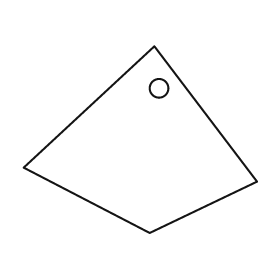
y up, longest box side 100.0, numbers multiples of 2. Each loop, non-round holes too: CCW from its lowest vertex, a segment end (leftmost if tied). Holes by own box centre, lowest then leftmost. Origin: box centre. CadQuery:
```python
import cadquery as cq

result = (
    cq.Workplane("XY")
    .moveTo(4.0, -40.0)
    .lineTo(50.0, -18.0)
    .lineTo(6.0, 40.0)
    .lineTo(-50.0, -12.0)
    .close()
    .moveTo(8.0, 22.0)
    .circle(4.0)
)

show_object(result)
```